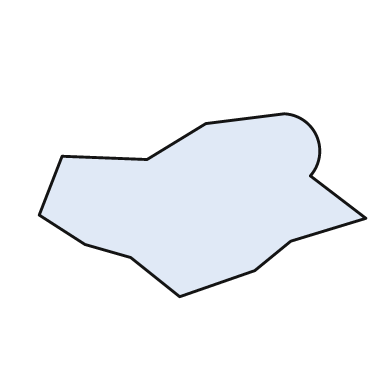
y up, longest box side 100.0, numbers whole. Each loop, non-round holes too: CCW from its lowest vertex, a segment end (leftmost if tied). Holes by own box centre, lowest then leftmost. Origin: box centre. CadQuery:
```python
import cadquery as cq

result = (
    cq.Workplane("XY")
    .moveTo(-7.0, -28.0)
    .lineTo(16.0, -20.0)
    .lineTo(27.0, -11.0)
    .lineTo(50.0, -4.0)
    .lineTo(33.0, 9.0)
    .threePointArc((35.0, 21.0), (25.0, 28.0))
    .lineTo(1.0, 25.0)
    .lineTo(-17.0, 14.0)
    .lineTo(-43.0, 15.0)
    .lineTo(-50.0, -3.0)
    .lineTo(-36.0, -12.0)
    .lineTo(-22.0, -16.0)
    .close()
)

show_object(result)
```